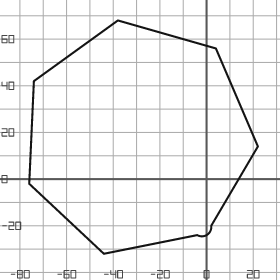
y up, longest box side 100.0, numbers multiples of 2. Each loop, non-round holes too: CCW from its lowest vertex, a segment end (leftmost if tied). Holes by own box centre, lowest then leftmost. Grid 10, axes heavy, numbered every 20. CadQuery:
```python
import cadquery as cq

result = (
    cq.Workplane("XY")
    .moveTo(-44.0, -32.0)
    .lineTo(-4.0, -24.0)
    .threePointArc((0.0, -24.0), (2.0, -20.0))
    .lineTo(22.0, 14.0)
    .lineTo(4.0, 56.0)
    .lineTo(-38.0, 68.0)
    .lineTo(-74.0, 42.0)
    .lineTo(-76.0, -2.0)
    .close()
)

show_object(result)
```